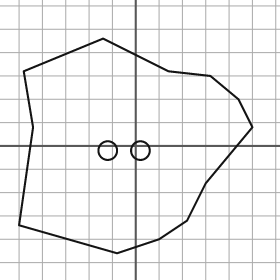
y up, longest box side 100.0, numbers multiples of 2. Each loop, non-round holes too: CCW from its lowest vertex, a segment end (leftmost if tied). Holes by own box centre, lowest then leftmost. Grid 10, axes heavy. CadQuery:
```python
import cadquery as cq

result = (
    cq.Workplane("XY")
    .moveTo(-8.0, -46.0)
    .lineTo(10.0, -40.0)
    .lineTo(22.0, -32.0)
    .lineTo(30.0, -16.0)
    .lineTo(50.0, 8.0)
    .lineTo(44.0, 20.0)
    .lineTo(32.0, 30.0)
    .lineTo(14.0, 32.0)
    .lineTo(-14.0, 46.0)
    .lineTo(-48.0, 32.0)
    .lineTo(-44.0, 8.0)
    .lineTo(-50.0, -34.0)
    .close()
    .moveTo(-12.0, -2.0)
    .circle(4.0)
    .moveTo(2.0, -2.0)
    .circle(4.0)
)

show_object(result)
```